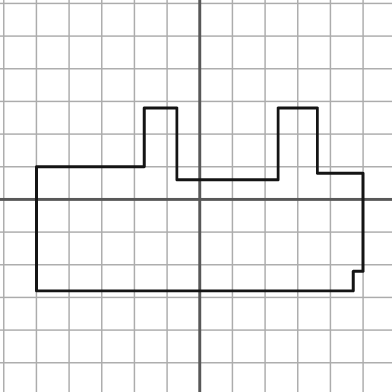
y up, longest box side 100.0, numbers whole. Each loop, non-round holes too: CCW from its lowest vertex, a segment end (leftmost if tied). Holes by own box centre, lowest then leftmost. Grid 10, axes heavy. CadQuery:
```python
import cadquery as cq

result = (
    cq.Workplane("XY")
    .moveTo(-50.0, -28.0)
    .lineTo(47.0, -28.0)
    .lineTo(47.0, -22.0)
    .lineTo(50.0, -22.0)
    .lineTo(50.0, 8.0)
    .lineTo(36.0, 8.0)
    .lineTo(36.0, 28.0)
    .lineTo(24.0, 28.0)
    .lineTo(24.0, 6.0)
    .lineTo(-7.0, 6.0)
    .lineTo(-7.0, 28.0)
    .lineTo(-17.0, 28.0)
    .lineTo(-17.0, 10.0)
    .lineTo(-50.0, 10.0)
    .close()
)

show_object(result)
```